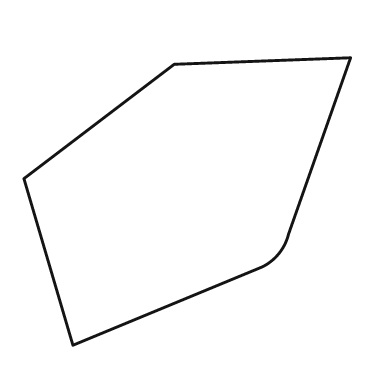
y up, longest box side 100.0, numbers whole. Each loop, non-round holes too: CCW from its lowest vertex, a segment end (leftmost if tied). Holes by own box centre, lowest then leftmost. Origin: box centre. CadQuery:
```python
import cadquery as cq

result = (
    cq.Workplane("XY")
    .moveTo(-35.0, -44.0)
    .lineTo(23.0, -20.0)
    .threePointArc((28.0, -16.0), (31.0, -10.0))
    .lineTo(50.0, 44.0)
    .lineTo(-4.0, 42.0)
    .lineTo(-50.0, 7.0)
    .close()
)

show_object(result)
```